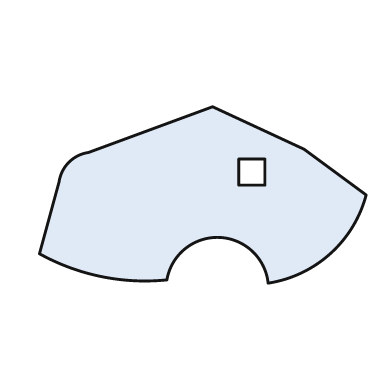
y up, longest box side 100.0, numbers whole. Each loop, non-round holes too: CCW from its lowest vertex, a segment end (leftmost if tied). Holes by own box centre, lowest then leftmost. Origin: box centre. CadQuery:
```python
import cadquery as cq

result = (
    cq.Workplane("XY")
    .moveTo(20.0, -27.0)
    .threePointArc((39.0, -18.0), (50.0, 0.0))
    .lineTo(31.0, 14.0)
    .lineTo(3.0, 27.0)
    .lineTo(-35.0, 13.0)
    .threePointArc((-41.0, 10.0), (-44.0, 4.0))
    .lineTo(-50.0, -18.0)
    .threePointArc((-31.0, -25.0), (-11.0, -26.0))
    .threePointArc((5.0, -13.0), (20.0, -27.0))
    .close()
    .moveTo(11.0, 3.0)
    .lineTo(19.0, 3.0)
    .lineTo(19.0, 11.0)
    .lineTo(11.0, 11.0)
    .close()
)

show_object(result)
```